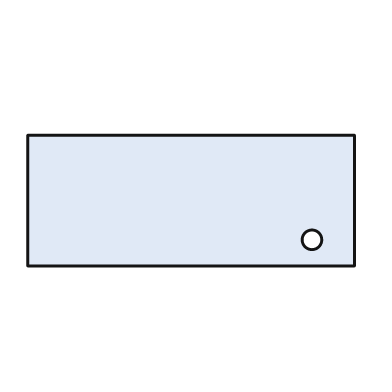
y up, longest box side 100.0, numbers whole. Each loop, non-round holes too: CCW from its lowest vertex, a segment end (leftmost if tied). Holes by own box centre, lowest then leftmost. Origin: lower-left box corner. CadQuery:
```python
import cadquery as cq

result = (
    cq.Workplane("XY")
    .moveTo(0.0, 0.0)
    .lineTo(100.0, 0.0)
    .lineTo(100.0, 40.0)
    .lineTo(0.0, 40.0)
    .close()
    .moveTo(87.0, 8.0)
    .circle(3.0)
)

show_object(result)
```